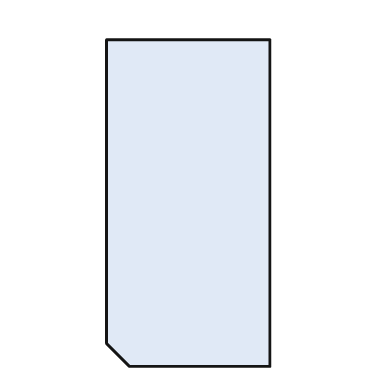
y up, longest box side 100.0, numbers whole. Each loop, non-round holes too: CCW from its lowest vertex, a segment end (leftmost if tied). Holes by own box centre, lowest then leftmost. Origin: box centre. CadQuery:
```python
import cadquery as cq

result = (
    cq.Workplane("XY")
    .moveTo(-18.0, -50.0)
    .lineTo(25.0, -50.0)
    .lineTo(25.0, 50.0)
    .lineTo(-25.0, 50.0)
    .lineTo(-25.0, -43.0)
    .close()
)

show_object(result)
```